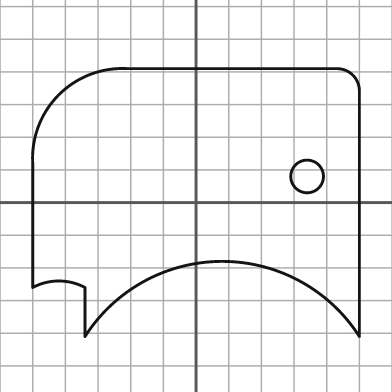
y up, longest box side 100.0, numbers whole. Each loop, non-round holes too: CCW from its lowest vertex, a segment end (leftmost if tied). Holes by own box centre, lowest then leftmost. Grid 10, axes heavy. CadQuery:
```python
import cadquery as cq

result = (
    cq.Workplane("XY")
    .moveTo(-34.0, -41.0)
    .threePointArc((8.0, -18.0), (50.0, -41.0))
    .lineTo(50.0, 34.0)
    .threePointArc((48.0, 39.0), (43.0, 41.0))
    .lineTo(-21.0, 41.0)
    .threePointArc((-42.0, 33.0), (-50.0, 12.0))
    .lineTo(-50.0, -26.0)
    .threePointArc((-42.0, -24.0), (-34.0, -26.0))
    .close()
    .moveTo(34.0, 8.0)
    .circle(5.0)
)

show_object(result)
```